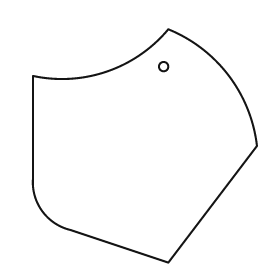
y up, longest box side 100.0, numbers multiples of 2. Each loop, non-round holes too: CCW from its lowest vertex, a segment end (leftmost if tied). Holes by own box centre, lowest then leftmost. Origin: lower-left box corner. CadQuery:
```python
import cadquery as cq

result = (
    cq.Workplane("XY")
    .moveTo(58.0, 0.0)
    .lineTo(96.0, 50.0)
    .threePointArc((84.0, 80.0), (58.0, 100.0))
    .threePointArc((32.0, 82.0), (0.0, 80.0))
    .lineTo(0.0, 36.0)
    .threePointArc((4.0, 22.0), (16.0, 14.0))
    .close()
    .moveTo(56.0, 84.0)
    .circle(2.0)
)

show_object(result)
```